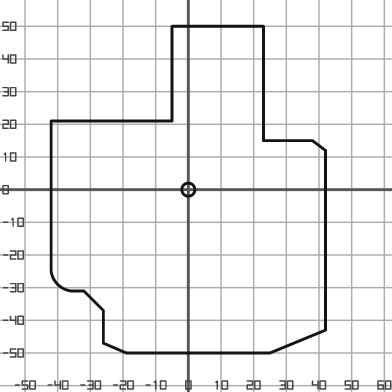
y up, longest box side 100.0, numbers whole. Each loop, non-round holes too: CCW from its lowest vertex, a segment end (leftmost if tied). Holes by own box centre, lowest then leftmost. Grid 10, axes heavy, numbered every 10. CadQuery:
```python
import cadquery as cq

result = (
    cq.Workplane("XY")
    .moveTo(-19.0, -50.0)
    .lineTo(25.0, -50.0)
    .lineTo(42.0, -43.0)
    .lineTo(42.0, 12.0)
    .lineTo(38.0, 15.0)
    .lineTo(23.0, 15.0)
    .lineTo(23.0, 50.0)
    .lineTo(-5.0, 50.0)
    .lineTo(-5.0, 21.0)
    .lineTo(-42.0, 21.0)
    .lineTo(-42.0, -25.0)
    .threePointArc((-40.0, -29.0), (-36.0, -31.0))
    .lineTo(-32.0, -31.0)
    .lineTo(-26.0, -37.0)
    .lineTo(-26.0, -47.0)
    .close()
    .moveTo(0.0, 0.0)
    .circle(2.0)
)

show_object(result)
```